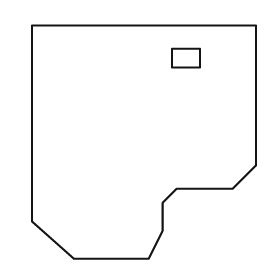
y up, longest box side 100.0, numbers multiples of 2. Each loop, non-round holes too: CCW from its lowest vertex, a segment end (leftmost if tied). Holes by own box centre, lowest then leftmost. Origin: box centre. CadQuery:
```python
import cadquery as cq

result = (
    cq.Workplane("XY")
    .moveTo(-30.0, -50.0)
    .lineTo(2.0, -50.0)
    .lineTo(8.0, -38.0)
    .lineTo(8.0, -26.0)
    .lineTo(14.0, -20.0)
    .lineTo(38.0, -20.0)
    .lineTo(48.0, -10.0)
    .lineTo(48.0, 50.0)
    .lineTo(-48.0, 50.0)
    .lineTo(-48.0, -34.0)
    .close()
    .moveTo(12.0, 32.0)
    .lineTo(24.0, 32.0)
    .lineTo(24.0, 40.0)
    .lineTo(12.0, 40.0)
    .close()
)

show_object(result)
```